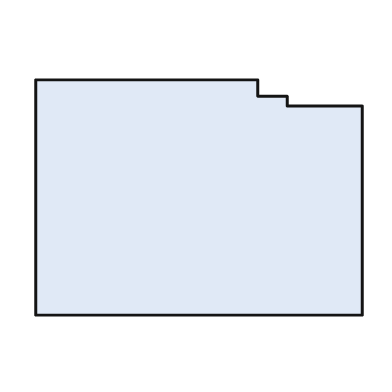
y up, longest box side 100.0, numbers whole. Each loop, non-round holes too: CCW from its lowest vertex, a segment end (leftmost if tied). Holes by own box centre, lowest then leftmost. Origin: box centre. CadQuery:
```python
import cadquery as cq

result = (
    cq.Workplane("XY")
    .moveTo(-50.0, -36.0)
    .lineTo(50.0, -36.0)
    .lineTo(50.0, 28.0)
    .lineTo(27.0, 28.0)
    .lineTo(27.0, 31.0)
    .lineTo(18.0, 31.0)
    .lineTo(18.0, 36.0)
    .lineTo(-50.0, 36.0)
    .close()
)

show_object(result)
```